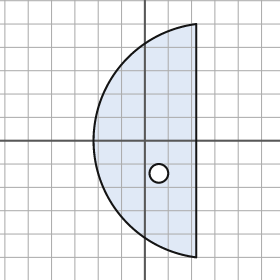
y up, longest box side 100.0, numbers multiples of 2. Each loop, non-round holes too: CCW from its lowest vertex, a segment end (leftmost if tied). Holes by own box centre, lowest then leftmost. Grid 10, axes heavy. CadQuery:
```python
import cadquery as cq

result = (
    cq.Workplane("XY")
    .moveTo(22.0, -50.0)
    .lineTo(22.0, 50.0)
    .threePointArc((-22.0, 0.0), (22.0, -50.0))
    .close()
    .moveTo(6.0, -14.0)
    .circle(4.0)
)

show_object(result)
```